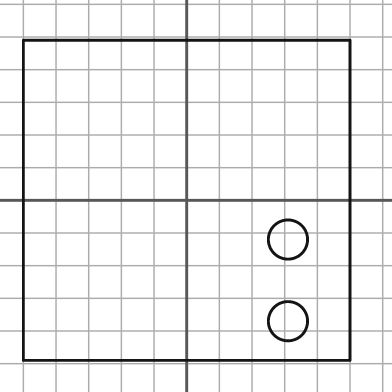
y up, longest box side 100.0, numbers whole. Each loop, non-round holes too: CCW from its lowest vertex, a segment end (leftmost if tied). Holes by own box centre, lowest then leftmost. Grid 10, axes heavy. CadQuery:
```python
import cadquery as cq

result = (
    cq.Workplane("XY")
    .moveTo(-50.0, -49.0)
    .lineTo(50.0, -49.0)
    .lineTo(50.0, 49.0)
    .lineTo(-50.0, 49.0)
    .close()
    .moveTo(31.0, -37.0)
    .circle(6.0)
    .moveTo(31.0, -12.0)
    .circle(6.0)
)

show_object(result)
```